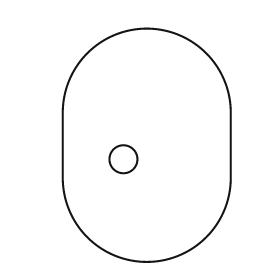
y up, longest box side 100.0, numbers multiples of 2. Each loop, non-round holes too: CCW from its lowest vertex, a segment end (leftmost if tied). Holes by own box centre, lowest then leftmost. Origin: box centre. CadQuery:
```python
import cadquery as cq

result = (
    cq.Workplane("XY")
    .moveTo(-36.0, -14.0)
    .threePointArc((0.0, -50.0), (36.0, -14.0))
    .lineTo(36.0, 14.0)
    .threePointArc((0.0, 50.0), (-36.0, 14.0))
    .close()
    .moveTo(-10.0, -6.0)
    .circle(6.0)
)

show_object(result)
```